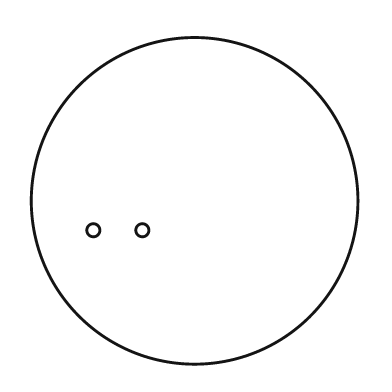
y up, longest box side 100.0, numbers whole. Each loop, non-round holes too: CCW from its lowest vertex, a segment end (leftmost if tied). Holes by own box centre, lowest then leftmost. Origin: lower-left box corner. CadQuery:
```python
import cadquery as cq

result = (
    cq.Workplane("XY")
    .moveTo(50.0, 50.0)
    .circle(50.0)
    .moveTo(19.0, 41.0)
    .circle(2.0)
    .moveTo(34.0, 41.0)
    .circle(2.0)
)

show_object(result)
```